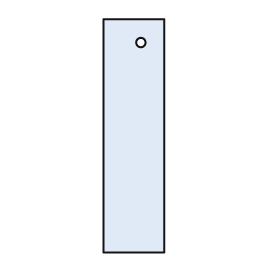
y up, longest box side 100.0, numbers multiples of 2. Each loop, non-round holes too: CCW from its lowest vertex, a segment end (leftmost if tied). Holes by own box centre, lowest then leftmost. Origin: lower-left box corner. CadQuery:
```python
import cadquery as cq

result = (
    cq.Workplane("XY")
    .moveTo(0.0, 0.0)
    .lineTo(26.0, 0.0)
    .lineTo(26.0, 100.0)
    .lineTo(0.0, 100.0)
    .close()
    .moveTo(16.0, 90.0)
    .circle(2.0)
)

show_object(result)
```